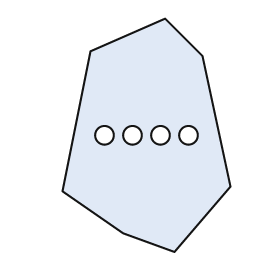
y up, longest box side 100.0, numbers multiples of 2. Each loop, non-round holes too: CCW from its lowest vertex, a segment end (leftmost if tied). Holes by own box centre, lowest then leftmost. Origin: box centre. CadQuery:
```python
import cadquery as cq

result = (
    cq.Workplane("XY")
    .moveTo(12.0, -50.0)
    .lineTo(36.0, -22.0)
    .lineTo(24.0, 34.0)
    .lineTo(8.0, 50.0)
    .lineTo(-24.0, 36.0)
    .lineTo(-36.0, -24.0)
    .lineTo(-10.0, -42.0)
    .close()
    .moveTo(-18.0, 0.0)
    .circle(4.0)
    .moveTo(-6.0, 0.0)
    .circle(4.0)
    .moveTo(6.0, 0.0)
    .circle(4.0)
    .moveTo(18.0, 0.0)
    .circle(4.0)
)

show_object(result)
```